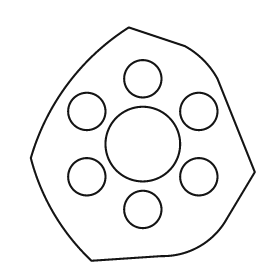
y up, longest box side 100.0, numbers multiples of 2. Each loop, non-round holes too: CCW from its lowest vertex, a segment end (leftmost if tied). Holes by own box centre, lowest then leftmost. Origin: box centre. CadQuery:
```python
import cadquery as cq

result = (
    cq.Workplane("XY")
    .moveTo(-22.0, -50.0)
    .lineTo(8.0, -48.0)
    .threePointArc((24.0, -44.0), (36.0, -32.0))
    .lineTo(48.0, -12.0)
    .lineTo(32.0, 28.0)
    .threePointArc((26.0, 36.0), (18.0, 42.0))
    .lineTo(-6.0, 50.0)
    .threePointArc((-32.0, 26.0), (-48.0, -6.0))
    .threePointArc((-38.0, -30.0), (-22.0, -50.0))
    .close()
    .moveTo(0.0, -28.0)
    .circle(8.0)
    .moveTo(-24.0, -14.0)
    .circle(8.0)
    .moveTo(24.0, -14.0)
    .circle(8.0)
    .moveTo(0.0, 0.0)
    .circle(16.0)
    .moveTo(-24.0, 14.0)
    .circle(8.0)
    .moveTo(24.0, 14.0)
    .circle(8.0)
    .moveTo(0.0, 28.0)
    .circle(8.0)
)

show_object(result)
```